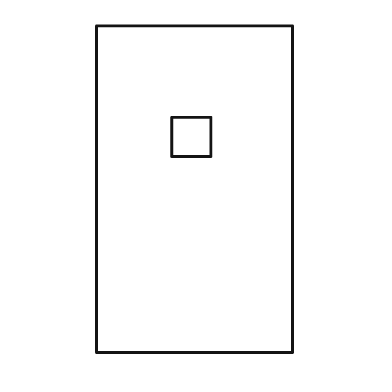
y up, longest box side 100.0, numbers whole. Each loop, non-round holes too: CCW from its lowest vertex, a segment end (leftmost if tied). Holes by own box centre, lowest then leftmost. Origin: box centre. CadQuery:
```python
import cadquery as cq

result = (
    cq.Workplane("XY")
    .moveTo(-30.0, -50.0)
    .lineTo(30.0, -50.0)
    .lineTo(30.0, 50.0)
    .lineTo(-30.0, 50.0)
    .close()
    .moveTo(-7.0, 10.0)
    .lineTo(5.0, 10.0)
    .lineTo(5.0, 22.0)
    .lineTo(-7.0, 22.0)
    .close()
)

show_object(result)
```